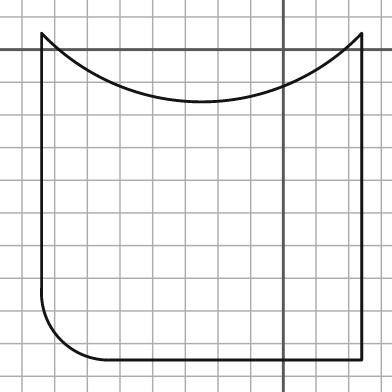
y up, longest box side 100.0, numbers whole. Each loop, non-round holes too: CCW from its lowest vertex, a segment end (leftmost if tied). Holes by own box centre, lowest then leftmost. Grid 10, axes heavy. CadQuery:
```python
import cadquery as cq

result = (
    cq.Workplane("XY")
    .moveTo(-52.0, -95.0)
    .lineTo(24.0, -95.0)
    .lineTo(24.0, 5.0)
    .threePointArc((-25.0, -16.0), (-74.0, 5.0))
    .lineTo(-74.0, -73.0)
    .threePointArc((-68.0, -89.0), (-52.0, -95.0))
    .close()
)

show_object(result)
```